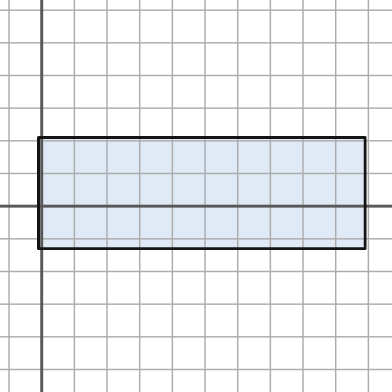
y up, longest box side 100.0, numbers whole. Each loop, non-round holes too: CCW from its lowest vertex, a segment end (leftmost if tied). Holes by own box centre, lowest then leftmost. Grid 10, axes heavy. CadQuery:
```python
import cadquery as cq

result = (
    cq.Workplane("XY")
    .moveTo(-1.0, -13.0)
    .lineTo(99.0, -13.0)
    .lineTo(99.0, 21.0)
    .lineTo(-1.0, 21.0)
    .close()
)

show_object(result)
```